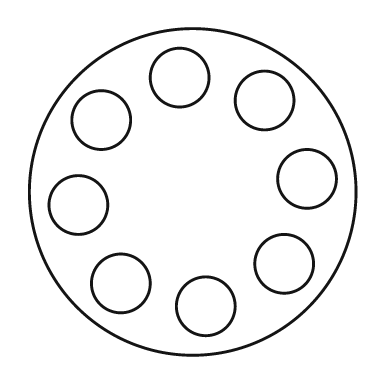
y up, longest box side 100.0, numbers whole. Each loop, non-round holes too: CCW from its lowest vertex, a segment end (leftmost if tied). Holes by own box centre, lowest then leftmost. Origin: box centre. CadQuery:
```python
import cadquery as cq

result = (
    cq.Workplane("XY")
    .moveTo(0.0, 0.0)
    .circle(50.0)
    .moveTo(4.0, -35.0)
    .circle(9.0)
    .moveTo(-22.0, -28.0)
    .circle(9.0)
    .moveTo(28.0, -22.0)
    .circle(9.0)
    .moveTo(-35.0, -4.0)
    .circle(9.0)
    .moveTo(35.0, 4.0)
    .circle(9.0)
    .moveTo(-28.0, 22.0)
    .circle(9.0)
    .moveTo(22.0, 28.0)
    .circle(9.0)
    .moveTo(-4.0, 35.0)
    .circle(9.0)
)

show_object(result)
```